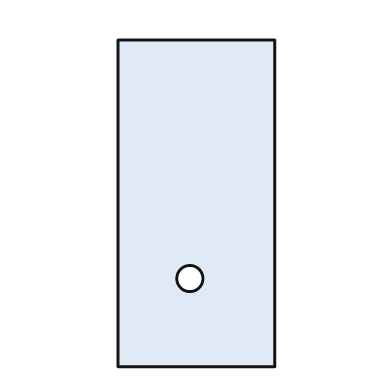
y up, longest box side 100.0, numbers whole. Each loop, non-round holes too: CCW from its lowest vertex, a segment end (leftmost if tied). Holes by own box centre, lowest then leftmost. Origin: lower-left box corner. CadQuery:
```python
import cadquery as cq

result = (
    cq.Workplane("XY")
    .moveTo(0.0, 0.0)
    .lineTo(48.0, 0.0)
    .lineTo(48.0, 100.0)
    .lineTo(0.0, 100.0)
    .close()
    .moveTo(22.0, 27.0)
    .circle(4.0)
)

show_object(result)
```